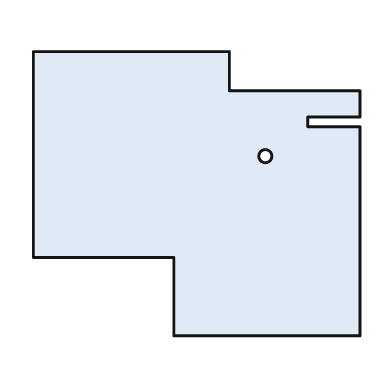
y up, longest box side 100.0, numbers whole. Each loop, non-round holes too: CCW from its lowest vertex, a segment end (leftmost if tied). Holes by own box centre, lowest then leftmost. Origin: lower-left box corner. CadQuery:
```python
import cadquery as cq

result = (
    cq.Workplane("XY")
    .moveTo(43.0, 0.0)
    .lineTo(100.0, 0.0)
    .lineTo(100.0, 64.0)
    .lineTo(84.0, 64.0)
    .lineTo(84.0, 67.0)
    .lineTo(100.0, 67.0)
    .lineTo(100.0, 75.0)
    .lineTo(60.0, 75.0)
    .lineTo(60.0, 87.0)
    .lineTo(0.0, 87.0)
    .lineTo(0.0, 24.0)
    .lineTo(43.0, 24.0)
    .close()
    .moveTo(71.0, 55.0)
    .circle(2.0)
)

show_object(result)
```